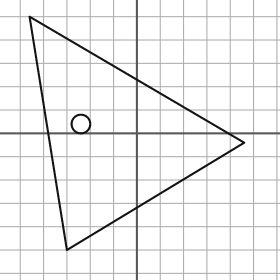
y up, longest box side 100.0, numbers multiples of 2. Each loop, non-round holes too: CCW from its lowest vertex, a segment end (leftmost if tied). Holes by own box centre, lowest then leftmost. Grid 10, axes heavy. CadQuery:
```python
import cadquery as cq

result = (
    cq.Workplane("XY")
    .moveTo(-30.0, -50.0)
    .lineTo(46.0, -4.0)
    .lineTo(-46.0, 50.0)
    .close()
    .moveTo(-24.0, 4.0)
    .circle(4.0)
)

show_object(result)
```